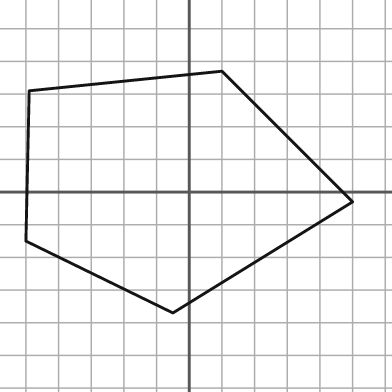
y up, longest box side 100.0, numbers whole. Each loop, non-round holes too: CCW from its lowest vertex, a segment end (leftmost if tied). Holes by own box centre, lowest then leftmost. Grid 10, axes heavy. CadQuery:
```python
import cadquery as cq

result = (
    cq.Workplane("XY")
    .moveTo(-5.0, -37.0)
    .lineTo(50.0, -3.0)
    .lineTo(10.0, 37.0)
    .lineTo(-49.0, 31.0)
    .lineTo(-50.0, -15.0)
    .close()
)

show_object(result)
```